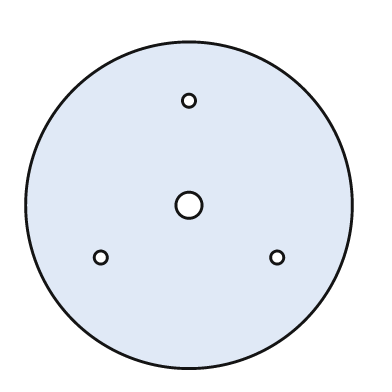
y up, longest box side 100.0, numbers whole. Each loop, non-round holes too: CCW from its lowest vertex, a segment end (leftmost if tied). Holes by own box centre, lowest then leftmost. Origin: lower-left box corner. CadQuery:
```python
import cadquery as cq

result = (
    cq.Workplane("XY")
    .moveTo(50.0, 50.0)
    .circle(50.0)
    .moveTo(23.0, 34.0)
    .circle(2.0)
    .moveTo(77.0, 34.0)
    .circle(2.0)
    .moveTo(50.0, 50.0)
    .circle(4.0)
    .moveTo(50.0, 82.0)
    .circle(2.0)
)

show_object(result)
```